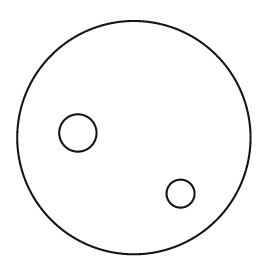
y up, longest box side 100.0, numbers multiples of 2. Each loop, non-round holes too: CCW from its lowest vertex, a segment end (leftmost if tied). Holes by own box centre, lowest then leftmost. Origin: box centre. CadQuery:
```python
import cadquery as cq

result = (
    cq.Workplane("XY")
    .moveTo(0.0, 0.0)
    .circle(50.0)
    .moveTo(20.0, -24.0)
    .circle(6.0)
    .moveTo(-24.0, 2.0)
    .circle(8.0)
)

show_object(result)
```